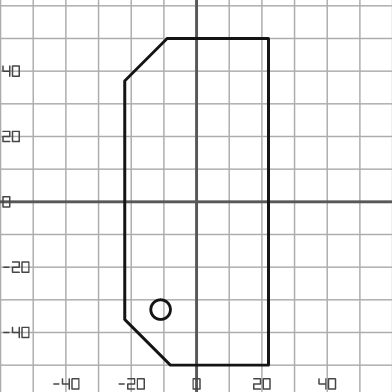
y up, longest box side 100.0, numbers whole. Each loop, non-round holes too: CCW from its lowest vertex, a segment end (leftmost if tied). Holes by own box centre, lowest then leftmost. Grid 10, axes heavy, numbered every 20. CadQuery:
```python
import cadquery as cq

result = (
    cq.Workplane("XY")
    .moveTo(-8.0, -50.0)
    .lineTo(22.0, -50.0)
    .lineTo(22.0, 50.0)
    .lineTo(-9.0, 50.0)
    .lineTo(-22.0, 37.0)
    .lineTo(-22.0, -36.0)
    .close()
    .moveTo(-11.0, -33.0)
    .circle(3.0)
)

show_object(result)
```